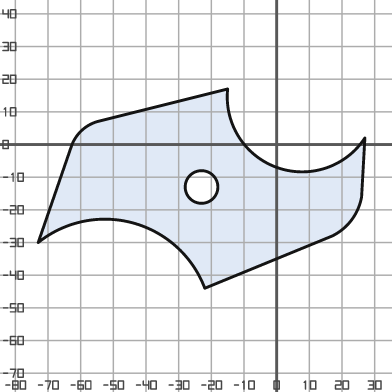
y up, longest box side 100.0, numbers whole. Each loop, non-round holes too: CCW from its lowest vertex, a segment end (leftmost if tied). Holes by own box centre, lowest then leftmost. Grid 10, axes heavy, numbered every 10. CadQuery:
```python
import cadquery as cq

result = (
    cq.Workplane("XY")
    .moveTo(-22.0, -44.0)
    .lineTo(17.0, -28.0)
    .threePointArc((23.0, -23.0), (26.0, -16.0))
    .lineTo(27.0, 2.0)
    .threePointArc((0.0, -7.0), (-15.0, 17.0))
    .lineTo(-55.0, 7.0)
    .threePointArc((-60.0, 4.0), (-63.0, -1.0))
    .lineTo(-73.0, -30.0)
    .threePointArc((-44.0, -24.0), (-22.0, -44.0))
    .close()
    .moveTo(-23.0, -13.0)
    .circle(5.0)
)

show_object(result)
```